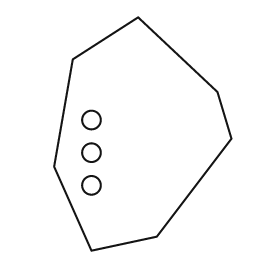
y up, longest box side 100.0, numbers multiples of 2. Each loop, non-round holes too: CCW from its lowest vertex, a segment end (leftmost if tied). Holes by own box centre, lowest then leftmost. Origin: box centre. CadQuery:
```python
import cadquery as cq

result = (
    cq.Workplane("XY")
    .moveTo(-22.0, -50.0)
    .lineTo(6.0, -44.0)
    .lineTo(38.0, -2.0)
    .lineTo(32.0, 18.0)
    .lineTo(-2.0, 50.0)
    .lineTo(-30.0, 32.0)
    .lineTo(-38.0, -14.0)
    .close()
    .moveTo(-22.0, -22.0)
    .circle(4.0)
    .moveTo(-22.0, -8.0)
    .circle(4.0)
    .moveTo(-22.0, 6.0)
    .circle(4.0)
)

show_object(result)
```